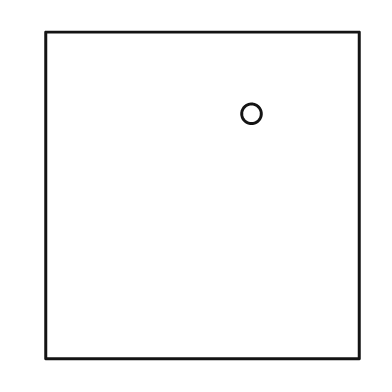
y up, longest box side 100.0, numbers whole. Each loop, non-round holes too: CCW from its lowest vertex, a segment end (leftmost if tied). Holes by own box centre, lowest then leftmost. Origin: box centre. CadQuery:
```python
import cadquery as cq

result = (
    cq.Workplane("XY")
    .moveTo(-48.0, -50.0)
    .lineTo(48.0, -50.0)
    .lineTo(48.0, 50.0)
    .lineTo(-48.0, 50.0)
    .close()
    .moveTo(15.0, 25.0)
    .circle(3.0)
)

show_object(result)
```